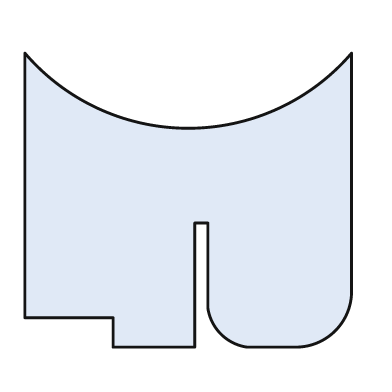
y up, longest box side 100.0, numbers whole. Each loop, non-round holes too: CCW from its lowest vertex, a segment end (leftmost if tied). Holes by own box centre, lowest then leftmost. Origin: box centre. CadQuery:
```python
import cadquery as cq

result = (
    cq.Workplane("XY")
    .moveTo(-23.0, -45.0)
    .lineTo(2.0, -45.0)
    .lineTo(2.0, -7.0)
    .lineTo(6.0, -7.0)
    .lineTo(6.0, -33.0)
    .threePointArc((10.0, -41.0), (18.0, -45.0))
    .lineTo(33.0, -45.0)
    .threePointArc((45.0, -40.0), (50.0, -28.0))
    .lineTo(50.0, 45.0)
    .threePointArc((0.0, 22.0), (-50.0, 45.0))
    .lineTo(-50.0, -36.0)
    .lineTo(-23.0, -36.0)
    .close()
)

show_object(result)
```